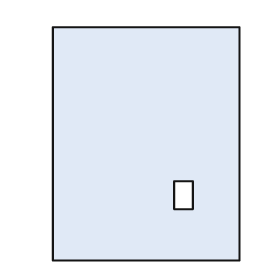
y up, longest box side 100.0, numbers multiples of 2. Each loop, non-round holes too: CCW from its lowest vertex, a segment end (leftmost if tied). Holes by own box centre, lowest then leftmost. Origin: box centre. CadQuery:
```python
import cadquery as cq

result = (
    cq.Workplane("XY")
    .moveTo(-40.0, -50.0)
    .lineTo(40.0, -50.0)
    .lineTo(40.0, 50.0)
    .lineTo(-40.0, 50.0)
    .close()
    .moveTo(12.0, -28.0)
    .lineTo(20.0, -28.0)
    .lineTo(20.0, -16.0)
    .lineTo(12.0, -16.0)
    .close()
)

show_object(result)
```